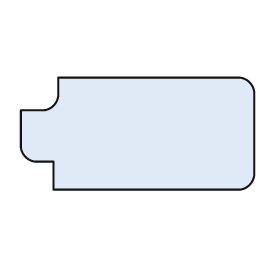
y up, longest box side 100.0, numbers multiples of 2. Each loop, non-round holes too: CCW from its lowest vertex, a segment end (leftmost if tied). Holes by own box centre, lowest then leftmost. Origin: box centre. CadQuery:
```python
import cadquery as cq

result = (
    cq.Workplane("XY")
    .moveTo(-36.0, -24.0)
    .lineTo(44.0, -24.0)
    .threePointArc((48.0, -22.0), (50.0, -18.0))
    .lineTo(50.0, 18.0)
    .threePointArc((48.0, 22.0), (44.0, 24.0))
    .lineTo(-34.0, 24.0)
    .lineTo(-34.0, 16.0)
    .threePointArc((-36.0, 12.0), (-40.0, 10.0))
    .lineTo(-50.0, 10.0)
    .lineTo(-50.0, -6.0)
    .threePointArc((-48.0, -10.0), (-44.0, -12.0))
    .lineTo(-36.0, -12.0)
    .close()
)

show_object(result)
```